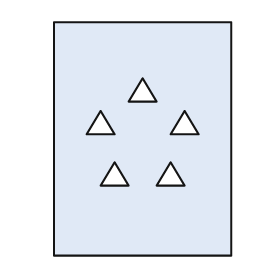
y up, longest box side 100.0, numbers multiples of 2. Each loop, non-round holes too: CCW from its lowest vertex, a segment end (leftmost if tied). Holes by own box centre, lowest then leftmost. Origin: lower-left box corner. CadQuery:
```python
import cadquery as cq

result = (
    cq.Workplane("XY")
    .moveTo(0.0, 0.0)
    .lineTo(76.0, 0.0)
    .lineTo(76.0, 100.0)
    .lineTo(0.0, 100.0)
    .close()
    .moveTo(20.0, 30.0)
    .lineTo(32.0, 30.0)
    .lineTo(26.0, 40.0)
    .close()
    .moveTo(44.0, 30.0)
    .lineTo(56.0, 30.0)
    .lineTo(50.0, 40.0)
    .close()
    .moveTo(14.0, 52.0)
    .lineTo(26.0, 52.0)
    .lineTo(20.0, 62.0)
    .close()
    .moveTo(50.0, 52.0)
    .lineTo(62.0, 52.0)
    .lineTo(56.0, 62.0)
    .close()
    .moveTo(32.0, 66.0)
    .lineTo(44.0, 66.0)
    .lineTo(38.0, 76.0)
    .close()
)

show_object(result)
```